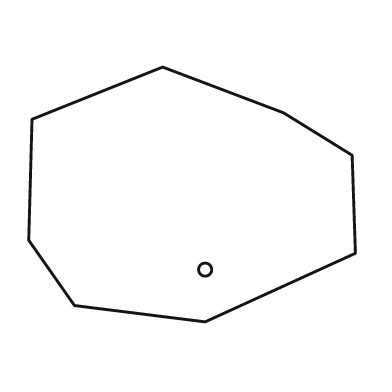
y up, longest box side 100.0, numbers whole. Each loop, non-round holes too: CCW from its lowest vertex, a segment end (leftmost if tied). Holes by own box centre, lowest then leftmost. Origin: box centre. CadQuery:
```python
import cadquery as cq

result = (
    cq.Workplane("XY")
    .moveTo(4.0, -39.0)
    .lineTo(50.0, -18.0)
    .lineTo(49.0, 12.0)
    .lineTo(28.0, 25.0)
    .lineTo(-9.0, 39.0)
    .lineTo(-49.0, 23.0)
    .lineTo(-50.0, -14.0)
    .lineTo(-36.0, -34.0)
    .close()
    .moveTo(4.0, -23.0)
    .circle(2.0)
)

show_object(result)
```